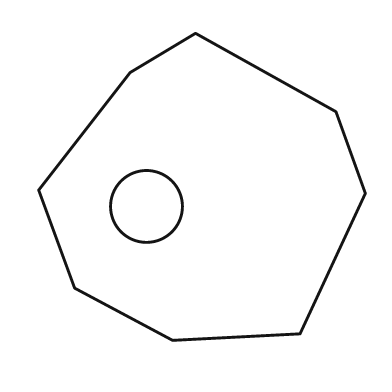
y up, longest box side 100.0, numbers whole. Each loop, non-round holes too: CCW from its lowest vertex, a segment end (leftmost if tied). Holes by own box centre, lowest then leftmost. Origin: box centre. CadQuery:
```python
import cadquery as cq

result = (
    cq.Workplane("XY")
    .moveTo(-9.0, -47.0)
    .lineTo(30.0, -45.0)
    .lineTo(50.0, -2.0)
    .lineTo(41.0, 23.0)
    .lineTo(-2.0, 47.0)
    .lineTo(-22.0, 35.0)
    .lineTo(-50.0, -1.0)
    .lineTo(-39.0, -31.0)
    .close()
    .moveTo(-17.0, -6.0)
    .circle(11.0)
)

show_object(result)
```